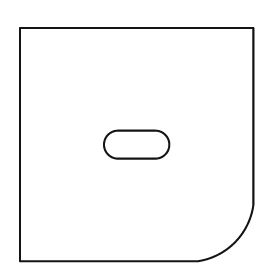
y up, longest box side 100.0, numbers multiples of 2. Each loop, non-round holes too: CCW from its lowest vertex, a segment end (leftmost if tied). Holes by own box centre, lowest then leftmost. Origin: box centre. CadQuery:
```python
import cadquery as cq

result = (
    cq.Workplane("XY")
    .moveTo(-50.0, -50.0)
    .lineTo(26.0, -50.0)
    .threePointArc((42.0, -42.0), (50.0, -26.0))
    .lineTo(50.0, 50.0)
    .lineTo(-50.0, 50.0)
    .close()
    .moveTo(-8.0, -6.0)
    .lineTo(8.0, -6.0)
    .threePointArc((14.0, 0.0), (8.0, 6.0))
    .lineTo(-8.0, 6.0)
    .threePointArc((-14.0, 0.0), (-8.0, -6.0))
    .close()
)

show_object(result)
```